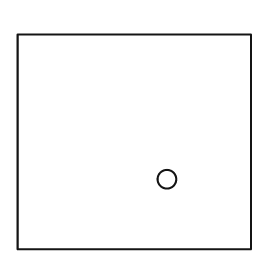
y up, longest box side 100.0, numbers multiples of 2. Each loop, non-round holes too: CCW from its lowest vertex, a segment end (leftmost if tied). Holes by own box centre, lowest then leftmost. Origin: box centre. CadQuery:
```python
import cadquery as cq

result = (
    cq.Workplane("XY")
    .moveTo(-50.0, -46.0)
    .lineTo(50.0, -46.0)
    .lineTo(50.0, 46.0)
    .lineTo(-50.0, 46.0)
    .close()
    .moveTo(14.0, -16.0)
    .circle(4.0)
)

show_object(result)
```